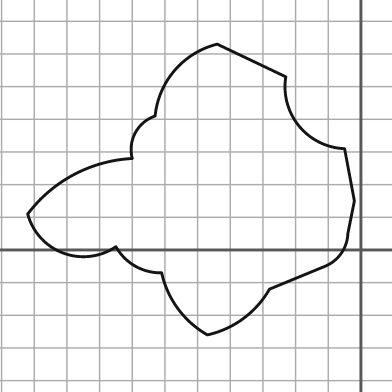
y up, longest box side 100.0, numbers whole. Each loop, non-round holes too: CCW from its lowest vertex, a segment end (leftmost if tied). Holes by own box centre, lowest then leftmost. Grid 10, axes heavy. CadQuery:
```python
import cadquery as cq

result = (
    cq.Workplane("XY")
    .moveTo(-47.0, -26.0)
    .threePointArc((-36.0, -21.0), (-28.0, -12.0))
    .lineTo(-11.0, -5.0)
    .threePointArc((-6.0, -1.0), (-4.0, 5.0))
    .lineTo(-2.0, 15.0)
    .lineTo(-5.0, 31.0)
    .threePointArc((-19.0, 38.0), (-23.0, 53.0))
    .lineTo(-44.0, 63.0)
    .threePointArc((-57.0, 55.0), (-63.0, 41.0))
    .threePointArc((-69.0, 36.0), (-70.0, 28.0))
    .threePointArc((-88.0, 23.0), (-102.0, 11.0))
    .threePointArc((-91.0, -1.0), (-75.0, 1.0))
    .threePointArc((-69.0, -5.0), (-61.0, -7.0))
    .threePointArc((-56.0, -18.0), (-47.0, -26.0))
    .close()
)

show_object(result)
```